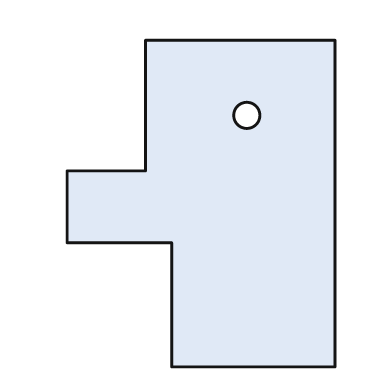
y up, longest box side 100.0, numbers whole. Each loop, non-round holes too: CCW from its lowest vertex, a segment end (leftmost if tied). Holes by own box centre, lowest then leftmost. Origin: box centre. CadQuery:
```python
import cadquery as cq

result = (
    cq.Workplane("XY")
    .moveTo(-9.0, -50.0)
    .lineTo(41.0, -50.0)
    .lineTo(41.0, 50.0)
    .lineTo(-17.0, 50.0)
    .lineTo(-17.0, 10.0)
    .lineTo(-41.0, 10.0)
    .lineTo(-41.0, -12.0)
    .lineTo(-9.0, -12.0)
    .close()
    .moveTo(14.0, 27.0)
    .circle(4.0)
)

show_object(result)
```